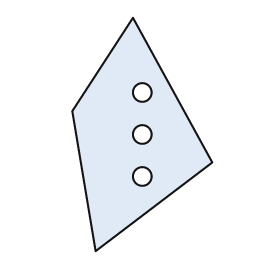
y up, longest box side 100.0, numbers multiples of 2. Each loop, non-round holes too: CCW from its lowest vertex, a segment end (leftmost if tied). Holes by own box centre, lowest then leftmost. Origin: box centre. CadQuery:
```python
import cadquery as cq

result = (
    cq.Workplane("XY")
    .moveTo(-20.0, -50.0)
    .lineTo(30.0, -12.0)
    .lineTo(-4.0, 50.0)
    .lineTo(-30.0, 10.0)
    .close()
    .moveTo(0.0, -18.0)
    .circle(4.0)
    .moveTo(0.0, 0.0)
    .circle(4.0)
    .moveTo(0.0, 18.0)
    .circle(4.0)
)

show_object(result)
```